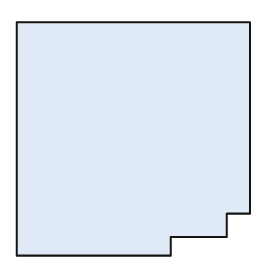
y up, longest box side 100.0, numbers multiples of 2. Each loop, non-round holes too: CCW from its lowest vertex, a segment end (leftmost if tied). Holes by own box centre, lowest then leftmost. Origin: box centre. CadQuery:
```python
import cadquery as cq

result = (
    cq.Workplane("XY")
    .moveTo(-50.0, -50.0)
    .lineTo(16.0, -50.0)
    .lineTo(16.0, -42.0)
    .lineTo(40.0, -42.0)
    .lineTo(40.0, -32.0)
    .lineTo(50.0, -32.0)
    .lineTo(50.0, 50.0)
    .lineTo(-50.0, 50.0)
    .close()
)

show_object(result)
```